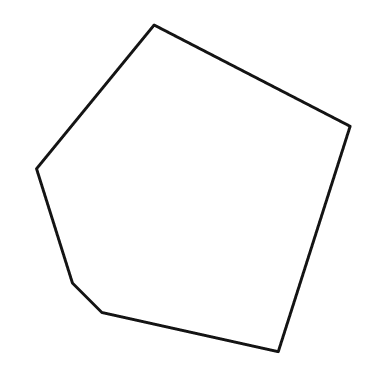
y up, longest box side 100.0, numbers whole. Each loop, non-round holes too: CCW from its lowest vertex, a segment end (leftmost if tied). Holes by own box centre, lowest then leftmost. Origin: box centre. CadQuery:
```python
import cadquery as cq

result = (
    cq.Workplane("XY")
    .moveTo(26.0, -50.0)
    .lineTo(48.0, 19.0)
    .lineTo(-12.0, 50.0)
    .lineTo(-48.0, 6.0)
    .lineTo(-37.0, -29.0)
    .lineTo(-28.0, -38.0)
    .close()
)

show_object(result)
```